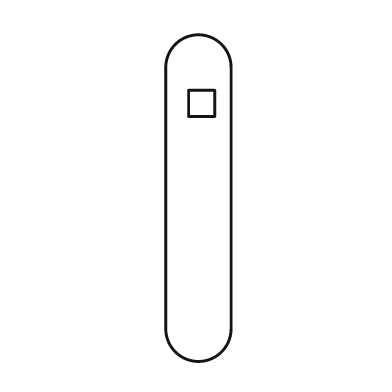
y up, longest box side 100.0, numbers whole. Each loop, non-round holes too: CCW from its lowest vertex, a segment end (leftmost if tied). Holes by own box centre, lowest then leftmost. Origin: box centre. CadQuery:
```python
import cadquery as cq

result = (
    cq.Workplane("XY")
    .moveTo(-10.0, -40.0)
    .threePointArc((0.0, -50.0), (10.0, -40.0))
    .lineTo(10.0, 40.0)
    .threePointArc((0.0, 50.0), (-10.0, 40.0))
    .close()
    .moveTo(-3.0, 25.0)
    .lineTo(5.0, 25.0)
    .lineTo(5.0, 33.0)
    .lineTo(-3.0, 33.0)
    .close()
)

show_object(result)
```